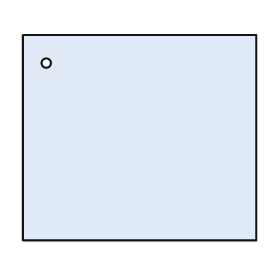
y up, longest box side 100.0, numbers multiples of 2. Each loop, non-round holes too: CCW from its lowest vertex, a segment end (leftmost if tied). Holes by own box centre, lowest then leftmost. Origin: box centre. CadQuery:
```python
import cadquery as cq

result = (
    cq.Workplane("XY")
    .moveTo(-50.0, -44.0)
    .lineTo(50.0, -44.0)
    .lineTo(50.0, 44.0)
    .lineTo(-50.0, 44.0)
    .close()
    .moveTo(-40.0, 32.0)
    .circle(2.0)
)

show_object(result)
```